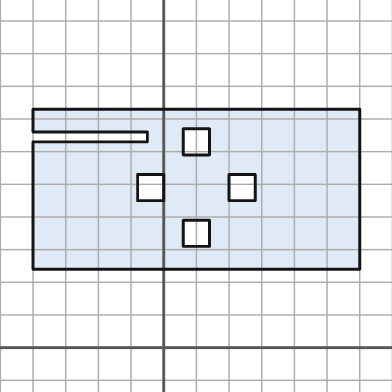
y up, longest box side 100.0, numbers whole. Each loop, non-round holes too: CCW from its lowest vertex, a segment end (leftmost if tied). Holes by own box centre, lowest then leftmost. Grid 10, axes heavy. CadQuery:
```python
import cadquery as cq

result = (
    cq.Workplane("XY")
    .moveTo(-40.0, 24.0)
    .lineTo(60.0, 24.0)
    .lineTo(60.0, 73.0)
    .lineTo(-40.0, 73.0)
    .lineTo(-40.0, 66.0)
    .lineTo(-5.0, 66.0)
    .lineTo(-5.0, 63.0)
    .lineTo(-40.0, 63.0)
    .close()
    .moveTo(6.0, 31.0)
    .lineTo(14.0, 31.0)
    .lineTo(14.0, 39.0)
    .lineTo(6.0, 39.0)
    .close()
    .moveTo(-8.0, 45.0)
    .lineTo(0.0, 45.0)
    .lineTo(0.0, 53.0)
    .lineTo(-8.0, 53.0)
    .close()
    .moveTo(20.0, 45.0)
    .lineTo(28.0, 45.0)
    .lineTo(28.0, 53.0)
    .lineTo(20.0, 53.0)
    .close()
    .moveTo(6.0, 59.0)
    .lineTo(14.0, 59.0)
    .lineTo(14.0, 67.0)
    .lineTo(6.0, 67.0)
    .close()
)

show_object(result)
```